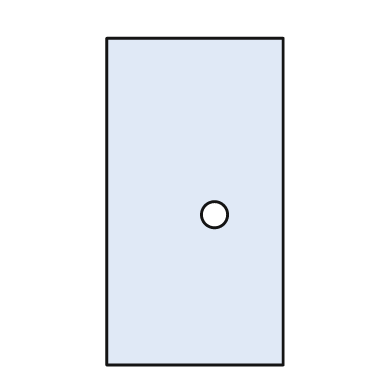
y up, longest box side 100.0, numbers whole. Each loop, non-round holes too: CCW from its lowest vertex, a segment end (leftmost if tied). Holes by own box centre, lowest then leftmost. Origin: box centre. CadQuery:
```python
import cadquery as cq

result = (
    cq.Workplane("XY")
    .moveTo(-27.0, -50.0)
    .lineTo(27.0, -50.0)
    .lineTo(27.0, 50.0)
    .lineTo(-27.0, 50.0)
    .close()
    .moveTo(6.0, -4.0)
    .circle(4.0)
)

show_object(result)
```